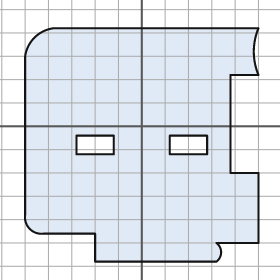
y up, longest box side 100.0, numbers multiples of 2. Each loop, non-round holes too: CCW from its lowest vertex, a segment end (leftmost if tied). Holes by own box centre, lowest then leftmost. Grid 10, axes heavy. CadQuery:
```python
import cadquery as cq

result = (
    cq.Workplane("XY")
    .moveTo(-20.0, -58.0)
    .lineTo(32.0, -58.0)
    .threePointArc((34.0, -54.0), (32.0, -50.0))
    .lineTo(50.0, -50.0)
    .lineTo(50.0, -20.0)
    .lineTo(38.0, -20.0)
    .lineTo(38.0, 22.0)
    .lineTo(50.0, 22.0)
    .threePointArc((48.0, 32.0), (50.0, 42.0))
    .lineTo(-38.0, 42.0)
    .threePointArc((-46.0, 38.0), (-50.0, 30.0))
    .lineTo(-50.0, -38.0)
    .threePointArc((-48.0, -44.0), (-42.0, -46.0))
    .lineTo(-20.0, -46.0)
    .close()
    .moveTo(-28.0, -12.0)
    .lineTo(-12.0, -12.0)
    .lineTo(-12.0, -4.0)
    .lineTo(-28.0, -4.0)
    .close()
    .moveTo(12.0, -12.0)
    .lineTo(28.0, -12.0)
    .lineTo(28.0, -4.0)
    .lineTo(12.0, -4.0)
    .close()
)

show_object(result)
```